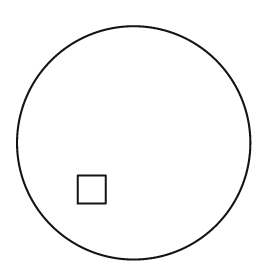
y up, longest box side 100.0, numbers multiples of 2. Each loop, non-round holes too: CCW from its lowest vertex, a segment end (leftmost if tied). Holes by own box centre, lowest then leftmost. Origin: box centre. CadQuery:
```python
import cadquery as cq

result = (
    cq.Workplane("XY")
    .moveTo(0.0, 0.0)
    .circle(50.0)
    .moveTo(-24.0, -26.0)
    .lineTo(-12.0, -26.0)
    .lineTo(-12.0, -14.0)
    .lineTo(-24.0, -14.0)
    .close()
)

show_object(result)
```